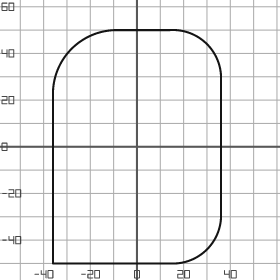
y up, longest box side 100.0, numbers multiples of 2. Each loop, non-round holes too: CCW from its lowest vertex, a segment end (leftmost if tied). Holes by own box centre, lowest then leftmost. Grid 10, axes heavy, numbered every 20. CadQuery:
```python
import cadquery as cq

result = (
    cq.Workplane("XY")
    .moveTo(-36.0, -50.0)
    .lineTo(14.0, -50.0)
    .threePointArc((30.0, -44.0), (36.0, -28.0))
    .lineTo(36.0, 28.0)
    .threePointArc((30.0, 44.0), (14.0, 50.0))
    .lineTo(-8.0, 50.0)
    .threePointArc((-28.0, 42.0), (-36.0, 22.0))
    .close()
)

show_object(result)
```